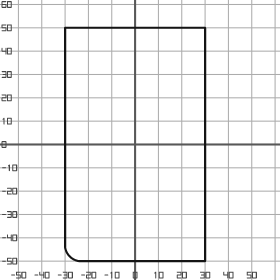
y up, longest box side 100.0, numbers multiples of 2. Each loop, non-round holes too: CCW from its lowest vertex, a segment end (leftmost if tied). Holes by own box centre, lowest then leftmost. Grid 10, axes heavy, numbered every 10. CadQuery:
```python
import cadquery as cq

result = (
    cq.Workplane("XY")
    .moveTo(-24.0, -50.0)
    .lineTo(30.0, -50.0)
    .lineTo(30.0, 50.0)
    .lineTo(-30.0, 50.0)
    .lineTo(-30.0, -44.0)
    .threePointArc((-28.0, -48.0), (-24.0, -50.0))
    .close()
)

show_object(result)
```